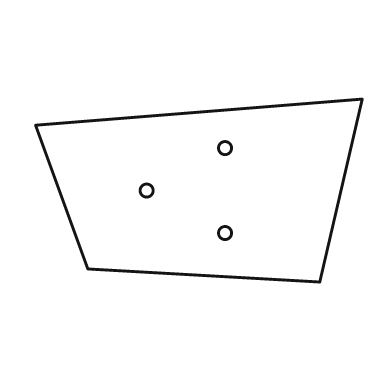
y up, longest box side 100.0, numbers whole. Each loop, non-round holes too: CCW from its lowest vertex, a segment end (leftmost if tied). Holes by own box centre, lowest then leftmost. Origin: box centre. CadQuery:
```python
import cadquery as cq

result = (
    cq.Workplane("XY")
    .moveTo(37.0, -28.0)
    .lineTo(50.0, 28.0)
    .lineTo(-50.0, 20.0)
    .lineTo(-34.0, -24.0)
    .close()
    .moveTo(8.0, -13.0)
    .circle(2.0)
    .moveTo(-16.0, 0.0)
    .circle(2.0)
    .moveTo(8.0, 13.0)
    .circle(2.0)
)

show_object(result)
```